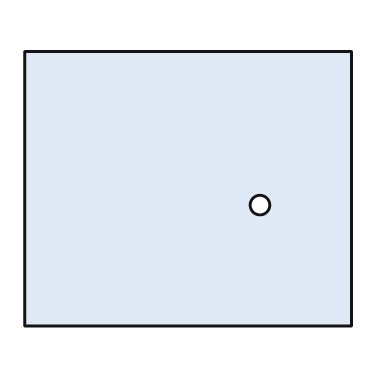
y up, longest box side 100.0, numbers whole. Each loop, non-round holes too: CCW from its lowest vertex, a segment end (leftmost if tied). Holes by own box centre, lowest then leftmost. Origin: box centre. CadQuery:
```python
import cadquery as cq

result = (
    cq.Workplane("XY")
    .moveTo(-50.0, -42.0)
    .lineTo(50.0, -42.0)
    .lineTo(50.0, 42.0)
    .lineTo(-50.0, 42.0)
    .close()
    .moveTo(22.0, -5.0)
    .circle(3.0)
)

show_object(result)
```